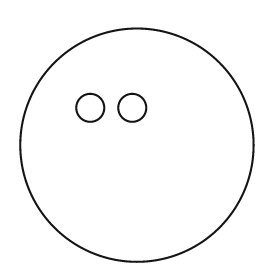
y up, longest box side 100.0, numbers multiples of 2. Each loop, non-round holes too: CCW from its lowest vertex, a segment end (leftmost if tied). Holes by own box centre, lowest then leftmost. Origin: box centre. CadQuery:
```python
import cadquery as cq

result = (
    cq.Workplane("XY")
    .moveTo(0.0, 0.0)
    .circle(50.0)
    .moveTo(-20.0, 16.0)
    .circle(6.0)
    .moveTo(-2.0, 16.0)
    .circle(6.0)
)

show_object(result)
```